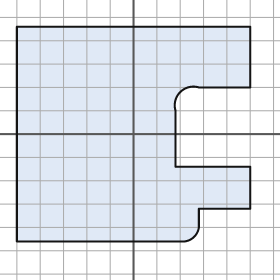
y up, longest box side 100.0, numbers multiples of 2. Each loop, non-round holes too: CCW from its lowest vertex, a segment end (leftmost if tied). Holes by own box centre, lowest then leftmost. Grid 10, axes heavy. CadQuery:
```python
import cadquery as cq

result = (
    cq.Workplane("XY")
    .moveTo(-50.0, -46.0)
    .lineTo(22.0, -46.0)
    .threePointArc((26.0, -44.0), (28.0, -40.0))
    .lineTo(28.0, -32.0)
    .lineTo(50.0, -32.0)
    .lineTo(50.0, -14.0)
    .lineTo(18.0, -14.0)
    .lineTo(18.0, 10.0)
    .threePointArc((20.0, 18.0), (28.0, 20.0))
    .lineTo(50.0, 20.0)
    .lineTo(50.0, 46.0)
    .lineTo(-50.0, 46.0)
    .close()
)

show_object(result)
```